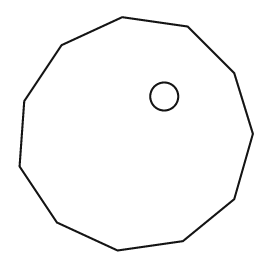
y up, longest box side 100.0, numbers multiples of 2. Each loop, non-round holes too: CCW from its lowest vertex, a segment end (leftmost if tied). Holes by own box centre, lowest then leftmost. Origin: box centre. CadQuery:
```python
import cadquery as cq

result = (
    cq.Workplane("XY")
    .moveTo(-8.0, -50.0)
    .lineTo(20.0, -46.0)
    .lineTo(42.0, -28.0)
    .lineTo(50.0, 0.0)
    .lineTo(42.0, 26.0)
    .lineTo(22.0, 46.0)
    .lineTo(-6.0, 50.0)
    .lineTo(-32.0, 38.0)
    .lineTo(-48.0, 14.0)
    .lineTo(-50.0, -14.0)
    .lineTo(-34.0, -38.0)
    .close()
    .moveTo(12.0, 16.0)
    .circle(6.0)
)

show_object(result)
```